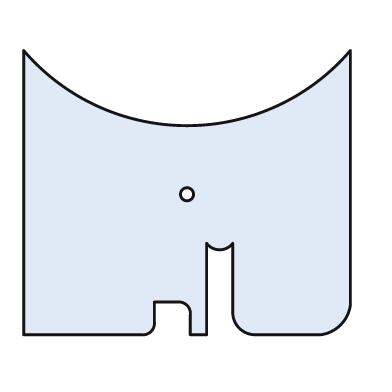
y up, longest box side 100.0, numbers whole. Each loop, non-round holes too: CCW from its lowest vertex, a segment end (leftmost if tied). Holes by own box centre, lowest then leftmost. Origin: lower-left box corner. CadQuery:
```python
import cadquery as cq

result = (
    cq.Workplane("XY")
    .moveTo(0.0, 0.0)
    .lineTo(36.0, 0.0)
    .threePointArc((39.0, 1.0), (40.0, 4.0))
    .lineTo(40.0, 10.0)
    .lineTo(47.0, 10.0)
    .threePointArc((50.0, 9.0), (51.0, 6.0))
    .lineTo(51.0, 0.0)
    .lineTo(56.0, 0.0)
    .lineTo(56.0, 28.0)
    .threePointArc((60.0, 26.0), (64.0, 28.0))
    .lineTo(64.0, 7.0)
    .threePointArc((66.0, 2.0), (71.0, 0.0))
    .lineTo(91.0, 0.0)
    .threePointArc((97.0, 3.0), (100.0, 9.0))
    .lineTo(100.0, 87.0)
    .threePointArc((50.0, 64.0), (0.0, 87.0))
    .close()
    .moveTo(50.0, 43.0)
    .circle(2.0)
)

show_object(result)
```